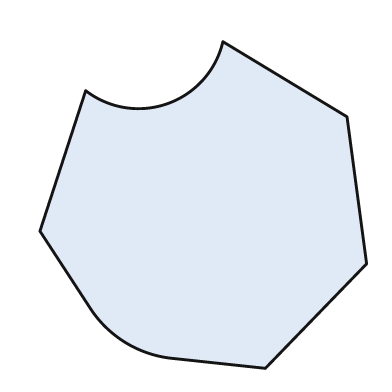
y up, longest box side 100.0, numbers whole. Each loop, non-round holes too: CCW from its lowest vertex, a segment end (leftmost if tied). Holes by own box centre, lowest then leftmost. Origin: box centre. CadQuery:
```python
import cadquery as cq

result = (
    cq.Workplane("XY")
    .moveTo(19.0, -50.0)
    .lineTo(50.0, -18.0)
    .lineTo(44.0, 27.0)
    .lineTo(6.0, 50.0)
    .threePointArc((-11.0, 31.0), (-36.0, 35.0))
    .lineTo(-50.0, -8.0)
    .lineTo(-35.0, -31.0)
    .threePointArc((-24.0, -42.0), (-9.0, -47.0))
    .close()
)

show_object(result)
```